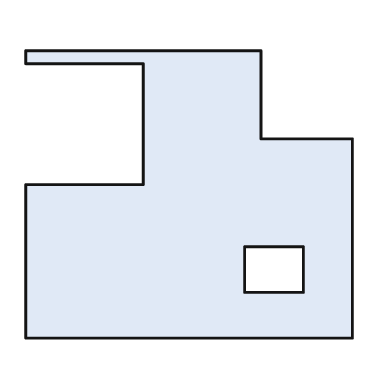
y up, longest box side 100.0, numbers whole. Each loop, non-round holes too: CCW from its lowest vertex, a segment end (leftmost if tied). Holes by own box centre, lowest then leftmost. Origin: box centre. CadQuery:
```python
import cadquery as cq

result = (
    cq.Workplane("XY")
    .moveTo(-50.0, -44.0)
    .lineTo(50.0, -44.0)
    .lineTo(50.0, 17.0)
    .lineTo(22.0, 17.0)
    .lineTo(22.0, 44.0)
    .lineTo(-50.0, 44.0)
    .lineTo(-50.0, 40.0)
    .lineTo(-14.0, 40.0)
    .lineTo(-14.0, 3.0)
    .lineTo(-50.0, 3.0)
    .close()
    .moveTo(17.0, -30.0)
    .lineTo(35.0, -30.0)
    .lineTo(35.0, -16.0)
    .lineTo(17.0, -16.0)
    .close()
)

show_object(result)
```